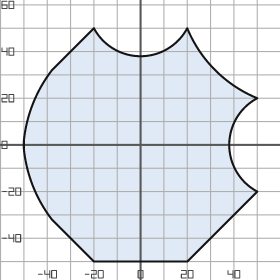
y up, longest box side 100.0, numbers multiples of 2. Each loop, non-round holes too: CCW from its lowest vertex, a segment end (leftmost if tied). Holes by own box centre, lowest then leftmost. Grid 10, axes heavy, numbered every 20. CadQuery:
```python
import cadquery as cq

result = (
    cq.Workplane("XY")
    .moveTo(-20.0, -50.0)
    .lineTo(20.0, -50.0)
    .lineTo(50.0, -20.0)
    .threePointArc((38.0, 0.0), (50.0, 20.0))
    .threePointArc((32.0, 32.0), (20.0, 50.0))
    .threePointArc((0.0, 38.0), (-20.0, 50.0))
    .lineTo(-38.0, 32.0)
    .threePointArc((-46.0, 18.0), (-50.0, 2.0))
    .lineTo(-50.0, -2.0)
    .threePointArc((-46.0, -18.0), (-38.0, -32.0))
    .close()
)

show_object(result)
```